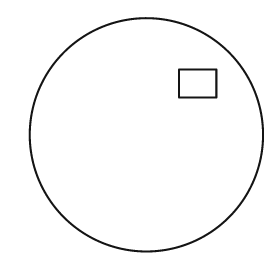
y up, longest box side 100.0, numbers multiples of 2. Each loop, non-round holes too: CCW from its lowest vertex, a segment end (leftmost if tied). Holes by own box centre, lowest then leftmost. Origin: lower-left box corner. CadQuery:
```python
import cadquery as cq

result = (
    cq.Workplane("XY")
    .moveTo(50.0, 50.0)
    .circle(50.0)
    .moveTo(64.0, 66.0)
    .lineTo(80.0, 66.0)
    .lineTo(80.0, 78.0)
    .lineTo(64.0, 78.0)
    .close()
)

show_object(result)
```